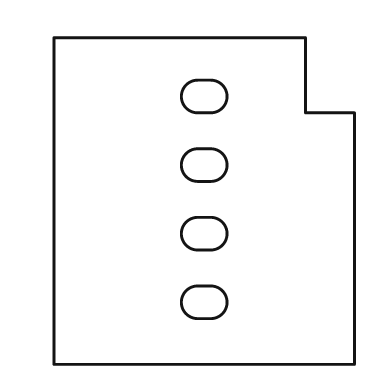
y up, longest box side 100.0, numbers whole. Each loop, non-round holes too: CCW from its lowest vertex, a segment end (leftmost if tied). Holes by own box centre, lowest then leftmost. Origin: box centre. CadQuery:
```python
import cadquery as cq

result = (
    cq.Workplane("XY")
    .moveTo(-46.0, -50.0)
    .lineTo(46.0, -50.0)
    .lineTo(46.0, 27.0)
    .lineTo(31.0, 27.0)
    .lineTo(31.0, 50.0)
    .lineTo(-46.0, 50.0)
    .close()
    .moveTo(-2.0, -36.0)
    .lineTo(2.0, -36.0)
    .threePointArc((7.0, -31.0), (2.0, -26.0))
    .lineTo(-2.0, -26.0)
    .threePointArc((-7.0, -31.0), (-2.0, -36.0))
    .close()
    .moveTo(-2.0, -15.0)
    .lineTo(2.0, -15.0)
    .threePointArc((7.0, -10.0), (2.0, -5.0))
    .lineTo(-2.0, -5.0)
    .threePointArc((-7.0, -10.0), (-2.0, -15.0))
    .close()
    .moveTo(-2.0, 6.0)
    .lineTo(2.0, 6.0)
    .threePointArc((7.0, 11.0), (2.0, 16.0))
    .lineTo(-2.0, 16.0)
    .threePointArc((-7.0, 11.0), (-2.0, 6.0))
    .close()
    .moveTo(-2.0, 27.0)
    .lineTo(2.0, 27.0)
    .threePointArc((7.0, 32.0), (2.0, 37.0))
    .lineTo(-2.0, 37.0)
    .threePointArc((-7.0, 32.0), (-2.0, 27.0))
    .close()
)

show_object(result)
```